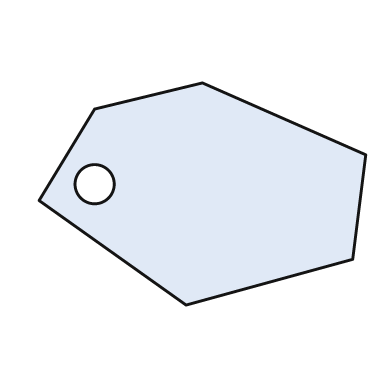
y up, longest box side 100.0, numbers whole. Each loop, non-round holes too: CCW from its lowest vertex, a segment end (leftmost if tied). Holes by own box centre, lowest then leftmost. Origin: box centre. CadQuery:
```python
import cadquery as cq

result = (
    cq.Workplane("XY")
    .moveTo(-5.0, -34.0)
    .lineTo(46.0, -20.0)
    .lineTo(50.0, 12.0)
    .lineTo(0.0, 34.0)
    .lineTo(-33.0, 26.0)
    .lineTo(-50.0, -2.0)
    .close()
    .moveTo(-33.0, 3.0)
    .circle(6.0)
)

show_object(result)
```